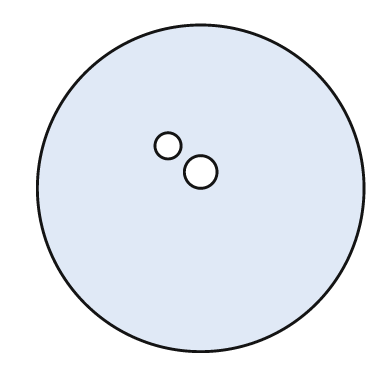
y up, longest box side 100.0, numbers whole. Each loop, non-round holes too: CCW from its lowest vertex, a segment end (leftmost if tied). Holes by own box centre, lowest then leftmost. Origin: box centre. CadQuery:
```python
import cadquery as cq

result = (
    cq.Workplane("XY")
    .moveTo(0.0, 0.0)
    .circle(50.0)
    .moveTo(0.0, 5.0)
    .circle(5.0)
    .moveTo(-10.0, 13.0)
    .circle(4.0)
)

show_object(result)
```